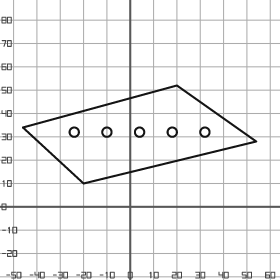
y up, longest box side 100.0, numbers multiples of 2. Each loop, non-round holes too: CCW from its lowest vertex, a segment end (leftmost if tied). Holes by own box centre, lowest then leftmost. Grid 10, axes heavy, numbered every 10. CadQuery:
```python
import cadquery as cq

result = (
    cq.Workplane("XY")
    .moveTo(-20.0, 10.0)
    .lineTo(54.0, 28.0)
    .lineTo(20.0, 52.0)
    .lineTo(-46.0, 34.0)
    .close()
    .moveTo(-24.0, 32.0)
    .circle(2.0)
    .moveTo(-10.0, 32.0)
    .circle(2.0)
    .moveTo(4.0, 32.0)
    .circle(2.0)
    .moveTo(18.0, 32.0)
    .circle(2.0)
    .moveTo(32.0, 32.0)
    .circle(2.0)
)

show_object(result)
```